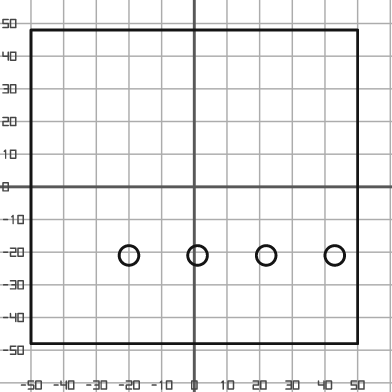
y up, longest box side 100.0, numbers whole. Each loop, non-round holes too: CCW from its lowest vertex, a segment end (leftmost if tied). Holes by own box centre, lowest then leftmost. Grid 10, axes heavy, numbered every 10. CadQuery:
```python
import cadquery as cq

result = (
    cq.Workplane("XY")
    .moveTo(-50.0, -48.0)
    .lineTo(50.0, -48.0)
    .lineTo(50.0, 48.0)
    .lineTo(-50.0, 48.0)
    .close()
    .moveTo(-20.0, -21.0)
    .circle(3.0)
    .moveTo(1.0, -21.0)
    .circle(3.0)
    .moveTo(22.0, -21.0)
    .circle(3.0)
    .moveTo(43.0, -21.0)
    .circle(3.0)
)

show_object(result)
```